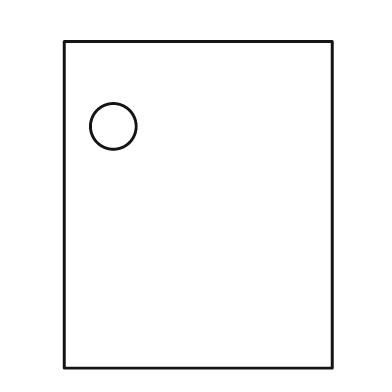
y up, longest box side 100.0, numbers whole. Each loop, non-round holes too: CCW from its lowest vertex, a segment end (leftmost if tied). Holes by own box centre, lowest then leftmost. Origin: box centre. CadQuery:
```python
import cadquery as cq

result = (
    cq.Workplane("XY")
    .moveTo(-41.0, -50.0)
    .lineTo(41.0, -50.0)
    .lineTo(41.0, 50.0)
    .lineTo(-41.0, 50.0)
    .close()
    .moveTo(-26.0, 24.0)
    .circle(7.0)
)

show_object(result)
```